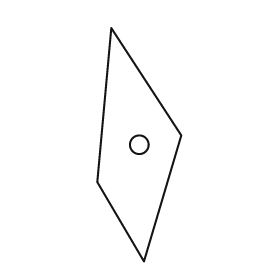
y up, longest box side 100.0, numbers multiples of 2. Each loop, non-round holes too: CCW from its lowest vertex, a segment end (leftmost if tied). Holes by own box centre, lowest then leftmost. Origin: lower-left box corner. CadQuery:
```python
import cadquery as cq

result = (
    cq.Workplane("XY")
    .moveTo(20.0, 0.0)
    .lineTo(36.0, 54.0)
    .lineTo(6.0, 100.0)
    .lineTo(0.0, 34.0)
    .close()
    .moveTo(18.0, 50.0)
    .circle(4.0)
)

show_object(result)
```